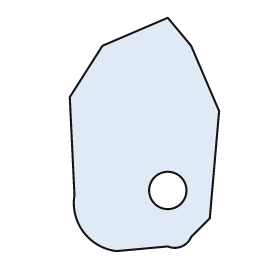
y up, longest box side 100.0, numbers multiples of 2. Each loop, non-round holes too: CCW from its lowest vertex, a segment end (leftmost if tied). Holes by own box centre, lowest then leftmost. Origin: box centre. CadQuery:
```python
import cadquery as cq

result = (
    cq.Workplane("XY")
    .moveTo(-12.0, -50.0)
    .lineTo(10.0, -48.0)
    .threePointArc((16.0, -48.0), (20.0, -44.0))
    .lineTo(28.0, -36.0)
    .lineTo(32.0, 10.0)
    .lineTo(20.0, 38.0)
    .lineTo(10.0, 50.0)
    .lineTo(-18.0, 38.0)
    .lineTo(-32.0, 16.0)
    .lineTo(-30.0, -26.0)
    .threePointArc((-26.0, -42.0), (-12.0, -50.0))
    .close()
    .moveTo(10.0, -24.0)
    .circle(8.0)
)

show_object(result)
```